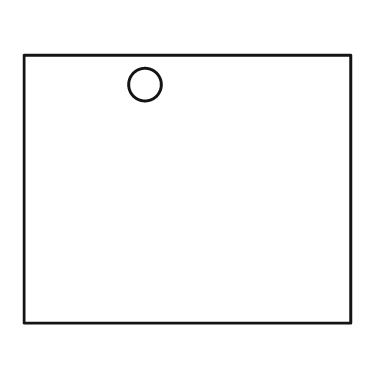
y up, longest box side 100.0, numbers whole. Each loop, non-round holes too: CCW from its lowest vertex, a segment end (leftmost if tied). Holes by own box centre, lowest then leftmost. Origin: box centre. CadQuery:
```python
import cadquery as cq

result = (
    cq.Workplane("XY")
    .moveTo(-50.0, -41.0)
    .lineTo(50.0, -41.0)
    .lineTo(50.0, 41.0)
    .lineTo(-50.0, 41.0)
    .close()
    .moveTo(-13.0, 32.0)
    .circle(5.0)
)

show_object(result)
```